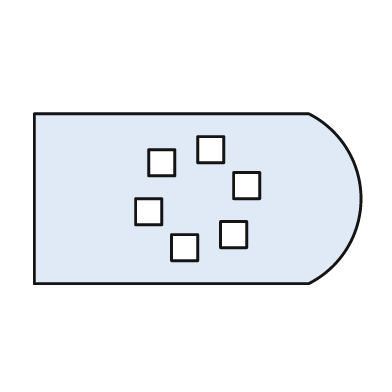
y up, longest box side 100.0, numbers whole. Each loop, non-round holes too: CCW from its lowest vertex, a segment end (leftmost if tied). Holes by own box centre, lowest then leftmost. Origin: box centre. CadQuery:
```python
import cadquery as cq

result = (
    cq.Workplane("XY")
    .moveTo(-50.0, -26.0)
    .lineTo(34.0, -26.0)
    .threePointArc((50.0, 0.0), (34.0, 26.0))
    .lineTo(-50.0, 26.0)
    .close()
    .moveTo(-8.0, -19.0)
    .lineTo(0.0, -19.0)
    .lineTo(0.0, -11.0)
    .lineTo(-8.0, -11.0)
    .close()
    .moveTo(7.0, -15.0)
    .lineTo(15.0, -15.0)
    .lineTo(15.0, -7.0)
    .lineTo(7.0, -7.0)
    .close()
    .moveTo(-19.0, -8.0)
    .lineTo(-11.0, -8.0)
    .lineTo(-11.0, 0.0)
    .lineTo(-19.0, 0.0)
    .close()
    .moveTo(11.0, 0.0)
    .lineTo(19.0, 0.0)
    .lineTo(19.0, 8.0)
    .lineTo(11.0, 8.0)
    .close()
    .moveTo(-15.0, 7.0)
    .lineTo(-7.0, 7.0)
    .lineTo(-7.0, 15.0)
    .lineTo(-15.0, 15.0)
    .close()
    .moveTo(0.0, 11.0)
    .lineTo(8.0, 11.0)
    .lineTo(8.0, 19.0)
    .lineTo(0.0, 19.0)
    .close()
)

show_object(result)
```